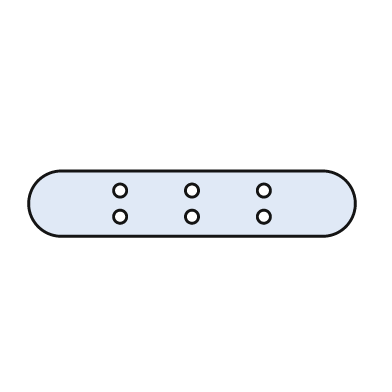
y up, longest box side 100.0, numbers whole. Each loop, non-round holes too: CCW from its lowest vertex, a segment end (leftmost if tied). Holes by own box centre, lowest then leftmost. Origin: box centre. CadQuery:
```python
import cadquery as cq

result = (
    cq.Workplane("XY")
    .moveTo(-40.0, -10.0)
    .lineTo(40.0, -10.0)
    .threePointArc((50.0, 0.0), (40.0, 10.0))
    .lineTo(-40.0, 10.0)
    .threePointArc((-50.0, 0.0), (-40.0, -10.0))
    .close()
    .moveTo(-22.0, -4.0)
    .circle(2.0)
    .moveTo(0.0, -4.0)
    .circle(2.0)
    .moveTo(22.0, -4.0)
    .circle(2.0)
    .moveTo(-22.0, 4.0)
    .circle(2.0)
    .moveTo(0.0, 4.0)
    .circle(2.0)
    .moveTo(22.0, 4.0)
    .circle(2.0)
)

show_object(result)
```